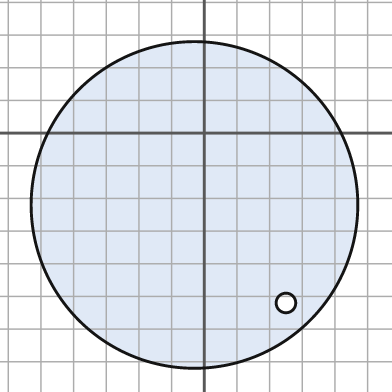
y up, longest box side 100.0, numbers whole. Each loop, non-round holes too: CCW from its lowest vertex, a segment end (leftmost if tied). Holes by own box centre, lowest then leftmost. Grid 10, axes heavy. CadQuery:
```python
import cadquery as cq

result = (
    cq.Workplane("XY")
    .moveTo(-3.0, -22.0)
    .circle(50.0)
    .moveTo(25.0, -52.0)
    .circle(3.0)
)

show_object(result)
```